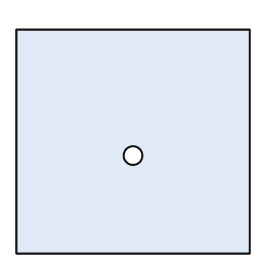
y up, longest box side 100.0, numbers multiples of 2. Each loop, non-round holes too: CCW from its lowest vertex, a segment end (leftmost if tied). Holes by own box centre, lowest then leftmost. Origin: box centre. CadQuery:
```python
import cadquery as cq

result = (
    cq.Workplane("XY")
    .moveTo(-50.0, -48.0)
    .lineTo(50.0, -48.0)
    .lineTo(50.0, 48.0)
    .lineTo(-50.0, 48.0)
    .close()
    .moveTo(0.0, -6.0)
    .circle(4.0)
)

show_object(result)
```